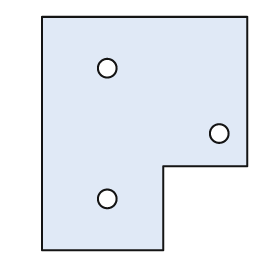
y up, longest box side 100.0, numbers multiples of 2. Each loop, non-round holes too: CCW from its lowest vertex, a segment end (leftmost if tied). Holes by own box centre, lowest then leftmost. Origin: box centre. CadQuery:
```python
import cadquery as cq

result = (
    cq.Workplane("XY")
    .moveTo(-44.0, -50.0)
    .lineTo(8.0, -50.0)
    .lineTo(8.0, -14.0)
    .lineTo(44.0, -14.0)
    .lineTo(44.0, 50.0)
    .lineTo(-44.0, 50.0)
    .close()
    .moveTo(-16.0, -28.0)
    .circle(4.0)
    .moveTo(32.0, 0.0)
    .circle(4.0)
    .moveTo(-16.0, 28.0)
    .circle(4.0)
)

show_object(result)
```